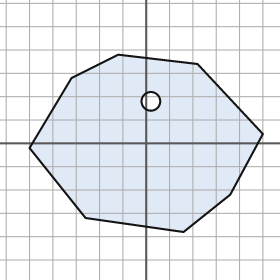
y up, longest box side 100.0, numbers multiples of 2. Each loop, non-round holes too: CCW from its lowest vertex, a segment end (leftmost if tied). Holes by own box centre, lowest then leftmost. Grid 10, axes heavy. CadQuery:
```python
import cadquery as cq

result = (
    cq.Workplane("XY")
    .moveTo(16.0, -38.0)
    .lineTo(36.0, -22.0)
    .lineTo(50.0, 4.0)
    .lineTo(22.0, 34.0)
    .lineTo(-12.0, 38.0)
    .lineTo(-32.0, 28.0)
    .lineTo(-50.0, -2.0)
    .lineTo(-26.0, -32.0)
    .close()
    .moveTo(2.0, 18.0)
    .circle(4.0)
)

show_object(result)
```